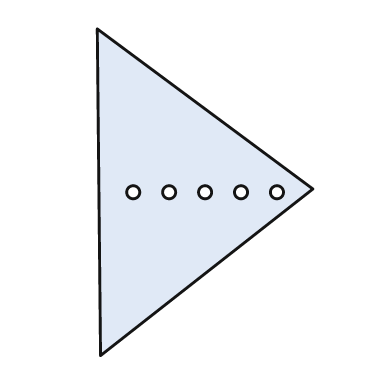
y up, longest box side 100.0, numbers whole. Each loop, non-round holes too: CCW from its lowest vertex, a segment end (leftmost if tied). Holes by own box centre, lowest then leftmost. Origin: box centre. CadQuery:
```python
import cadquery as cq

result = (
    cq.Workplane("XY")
    .moveTo(-32.0, -50.0)
    .lineTo(33.0, 1.0)
    .lineTo(-33.0, 50.0)
    .close()
    .moveTo(-22.0, 0.0)
    .circle(2.0)
    .moveTo(-11.0, 0.0)
    .circle(2.0)
    .moveTo(0.0, 0.0)
    .circle(2.0)
    .moveTo(11.0, 0.0)
    .circle(2.0)
    .moveTo(22.0, 0.0)
    .circle(2.0)
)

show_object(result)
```